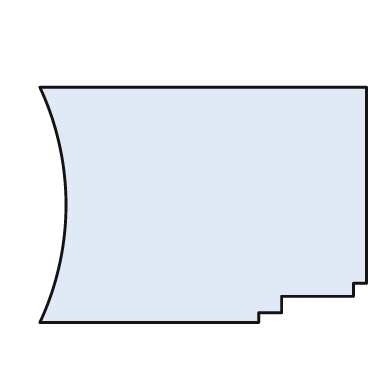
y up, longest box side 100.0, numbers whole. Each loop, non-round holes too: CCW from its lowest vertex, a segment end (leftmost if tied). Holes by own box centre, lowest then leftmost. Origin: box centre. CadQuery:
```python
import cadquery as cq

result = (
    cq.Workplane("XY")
    .moveTo(-50.0, -36.0)
    .lineTo(17.0, -36.0)
    .lineTo(17.0, -33.0)
    .lineTo(24.0, -33.0)
    .lineTo(24.0, -28.0)
    .lineTo(46.0, -28.0)
    .lineTo(46.0, -24.0)
    .lineTo(50.0, -24.0)
    .lineTo(50.0, 36.0)
    .lineTo(-50.0, 36.0)
    .threePointArc((-42.0, 0.0), (-50.0, -36.0))
    .close()
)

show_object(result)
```